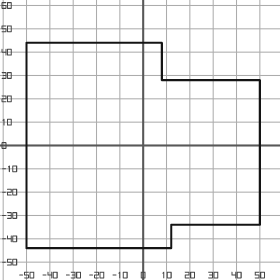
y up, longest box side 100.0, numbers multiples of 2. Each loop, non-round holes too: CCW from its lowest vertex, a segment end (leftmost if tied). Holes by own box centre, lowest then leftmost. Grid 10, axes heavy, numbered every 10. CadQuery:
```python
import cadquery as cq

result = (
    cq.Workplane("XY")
    .moveTo(-50.0, -44.0)
    .lineTo(12.0, -44.0)
    .lineTo(12.0, -34.0)
    .lineTo(50.0, -34.0)
    .lineTo(50.0, 28.0)
    .lineTo(8.0, 28.0)
    .lineTo(8.0, 44.0)
    .lineTo(-50.0, 44.0)
    .close()
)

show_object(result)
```